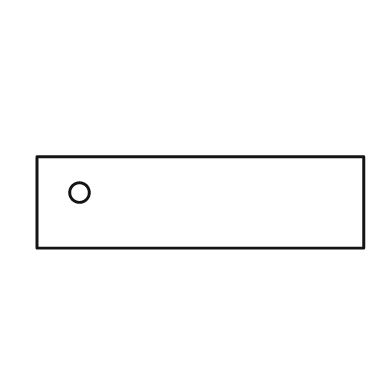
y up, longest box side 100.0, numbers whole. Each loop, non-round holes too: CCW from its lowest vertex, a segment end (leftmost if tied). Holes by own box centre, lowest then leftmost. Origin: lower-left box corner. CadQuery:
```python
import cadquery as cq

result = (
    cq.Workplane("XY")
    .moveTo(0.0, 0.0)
    .lineTo(100.0, 0.0)
    .lineTo(100.0, 28.0)
    .lineTo(0.0, 28.0)
    .close()
    .moveTo(13.0, 17.0)
    .circle(3.0)
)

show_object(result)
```